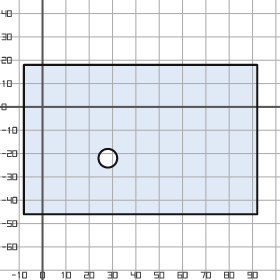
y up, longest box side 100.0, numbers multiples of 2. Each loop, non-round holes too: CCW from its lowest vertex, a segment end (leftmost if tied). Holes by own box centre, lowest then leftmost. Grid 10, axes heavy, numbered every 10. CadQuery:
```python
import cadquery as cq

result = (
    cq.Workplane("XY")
    .moveTo(-8.0, -46.0)
    .lineTo(92.0, -46.0)
    .lineTo(92.0, 18.0)
    .lineTo(-8.0, 18.0)
    .close()
    .moveTo(28.0, -22.0)
    .circle(4.0)
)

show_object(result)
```